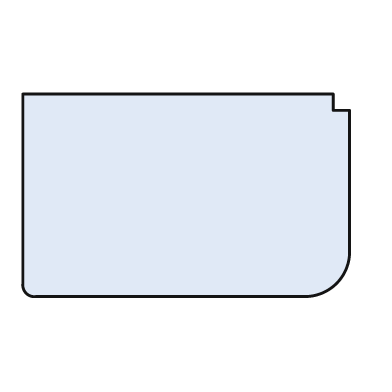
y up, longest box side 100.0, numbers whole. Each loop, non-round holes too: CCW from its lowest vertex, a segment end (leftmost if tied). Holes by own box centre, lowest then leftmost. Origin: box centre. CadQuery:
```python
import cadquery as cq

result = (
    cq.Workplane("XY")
    .moveTo(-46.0, -31.0)
    .lineTo(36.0, -31.0)
    .threePointArc((46.0, -27.0), (50.0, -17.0))
    .lineTo(50.0, 26.0)
    .lineTo(45.0, 26.0)
    .lineTo(45.0, 31.0)
    .lineTo(-50.0, 31.0)
    .lineTo(-50.0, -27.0)
    .threePointArc((-49.0, -30.0), (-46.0, -31.0))
    .close()
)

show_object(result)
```